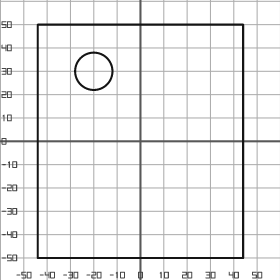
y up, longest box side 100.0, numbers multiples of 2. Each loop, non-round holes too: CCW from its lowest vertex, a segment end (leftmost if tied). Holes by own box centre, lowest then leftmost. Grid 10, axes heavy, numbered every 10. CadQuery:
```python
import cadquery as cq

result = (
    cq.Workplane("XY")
    .moveTo(-44.0, -50.0)
    .lineTo(44.0, -50.0)
    .lineTo(44.0, 50.0)
    .lineTo(-44.0, 50.0)
    .close()
    .moveTo(-20.0, 30.0)
    .circle(8.0)
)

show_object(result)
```